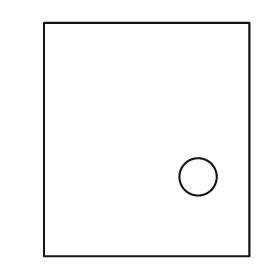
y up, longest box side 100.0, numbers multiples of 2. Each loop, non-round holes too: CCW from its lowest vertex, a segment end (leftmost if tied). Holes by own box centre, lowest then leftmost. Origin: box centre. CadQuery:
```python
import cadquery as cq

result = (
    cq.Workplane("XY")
    .moveTo(-44.0, -50.0)
    .lineTo(44.0, -50.0)
    .lineTo(44.0, 50.0)
    .lineTo(-44.0, 50.0)
    .close()
    .moveTo(22.0, -16.0)
    .circle(8.0)
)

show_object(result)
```